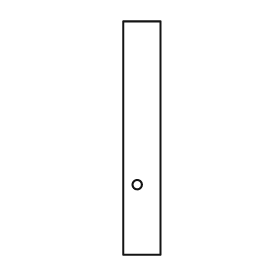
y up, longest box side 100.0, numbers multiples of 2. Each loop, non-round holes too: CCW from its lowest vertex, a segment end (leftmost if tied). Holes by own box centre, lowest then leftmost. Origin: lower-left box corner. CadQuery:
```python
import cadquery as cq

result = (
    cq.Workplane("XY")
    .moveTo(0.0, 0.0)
    .lineTo(16.0, 0.0)
    .lineTo(16.0, 100.0)
    .lineTo(0.0, 100.0)
    .close()
    .moveTo(6.0, 30.0)
    .circle(2.0)
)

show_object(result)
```